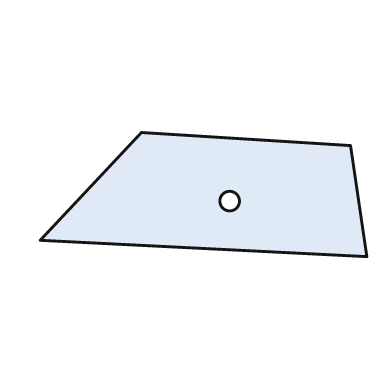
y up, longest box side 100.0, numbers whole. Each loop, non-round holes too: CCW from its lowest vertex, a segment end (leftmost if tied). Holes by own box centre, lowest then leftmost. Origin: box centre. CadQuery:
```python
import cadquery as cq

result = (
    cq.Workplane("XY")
    .moveTo(50.0, -19.0)
    .lineTo(45.0, 15.0)
    .lineTo(-19.0, 19.0)
    .lineTo(-50.0, -14.0)
    .close()
    .moveTo(8.0, -2.0)
    .circle(3.0)
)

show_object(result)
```